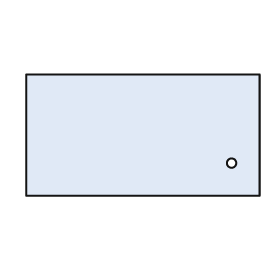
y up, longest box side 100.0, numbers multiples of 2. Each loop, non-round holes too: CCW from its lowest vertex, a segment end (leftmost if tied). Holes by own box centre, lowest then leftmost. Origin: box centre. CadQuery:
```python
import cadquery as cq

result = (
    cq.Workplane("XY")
    .moveTo(-50.0, -26.0)
    .lineTo(50.0, -26.0)
    .lineTo(50.0, 26.0)
    .lineTo(-50.0, 26.0)
    .close()
    .moveTo(38.0, -12.0)
    .circle(2.0)
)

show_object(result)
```